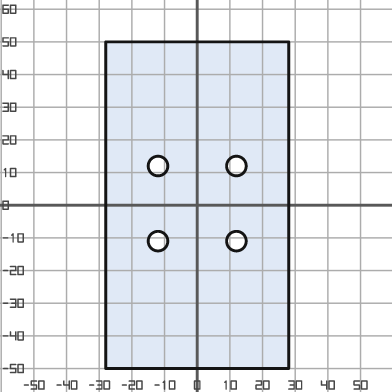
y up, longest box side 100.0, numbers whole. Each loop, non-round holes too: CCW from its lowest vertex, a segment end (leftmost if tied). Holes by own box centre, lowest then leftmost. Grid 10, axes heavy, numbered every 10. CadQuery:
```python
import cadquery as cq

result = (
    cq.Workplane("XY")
    .moveTo(-28.0, -50.0)
    .lineTo(28.0, -50.0)
    .lineTo(28.0, 50.0)
    .lineTo(-28.0, 50.0)
    .close()
    .moveTo(-12.0, -11.0)
    .circle(3.0)
    .moveTo(12.0, -11.0)
    .circle(3.0)
    .moveTo(-12.0, 12.0)
    .circle(3.0)
    .moveTo(12.0, 12.0)
    .circle(3.0)
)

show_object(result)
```